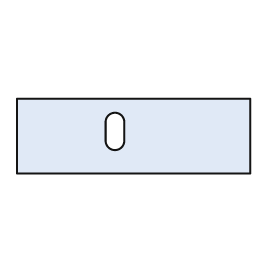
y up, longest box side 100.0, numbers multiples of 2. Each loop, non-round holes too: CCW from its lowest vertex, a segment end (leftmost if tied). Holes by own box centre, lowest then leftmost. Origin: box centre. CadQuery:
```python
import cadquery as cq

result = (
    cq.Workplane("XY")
    .moveTo(-50.0, -16.0)
    .lineTo(50.0, -16.0)
    .lineTo(50.0, 16.0)
    .lineTo(-50.0, 16.0)
    .close()
    .moveTo(-12.0, -2.0)
    .threePointArc((-8.0, -6.0), (-4.0, -2.0))
    .lineTo(-4.0, 6.0)
    .threePointArc((-8.0, 10.0), (-12.0, 6.0))
    .close()
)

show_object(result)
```